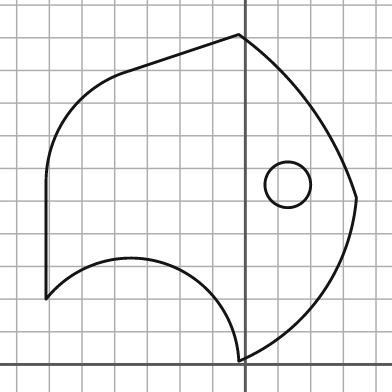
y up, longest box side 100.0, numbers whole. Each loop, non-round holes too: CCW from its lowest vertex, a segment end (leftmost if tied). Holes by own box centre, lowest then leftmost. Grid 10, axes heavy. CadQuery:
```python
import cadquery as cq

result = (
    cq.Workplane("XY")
    .moveTo(-2.0, 1.0)
    .threePointArc((23.0, 21.0), (34.0, 51.0))
    .threePointArc((20.0, 79.0), (-2.0, 101.0))
    .lineTo(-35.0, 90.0)
    .threePointArc((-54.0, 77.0), (-61.0, 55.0))
    .lineTo(-61.0, 20.0)
    .threePointArc((-25.0, 31.0), (-2.0, 1.0))
    .close()
    .moveTo(13.0, 55.0)
    .circle(7.0)
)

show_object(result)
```